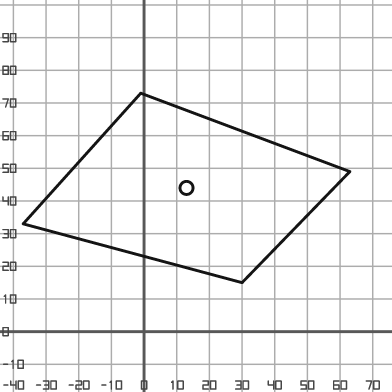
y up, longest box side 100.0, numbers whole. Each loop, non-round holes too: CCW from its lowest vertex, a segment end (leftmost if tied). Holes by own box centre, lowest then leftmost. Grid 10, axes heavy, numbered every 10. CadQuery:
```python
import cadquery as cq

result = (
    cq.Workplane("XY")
    .moveTo(30.0, 15.0)
    .lineTo(63.0, 49.0)
    .lineTo(-1.0, 73.0)
    .lineTo(-37.0, 33.0)
    .close()
    .moveTo(13.0, 44.0)
    .circle(2.0)
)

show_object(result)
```